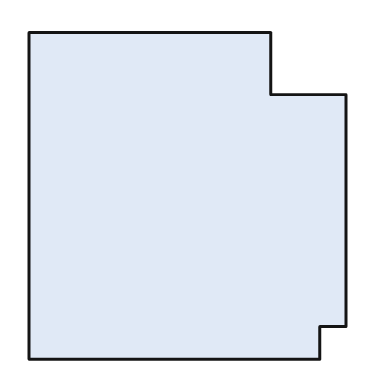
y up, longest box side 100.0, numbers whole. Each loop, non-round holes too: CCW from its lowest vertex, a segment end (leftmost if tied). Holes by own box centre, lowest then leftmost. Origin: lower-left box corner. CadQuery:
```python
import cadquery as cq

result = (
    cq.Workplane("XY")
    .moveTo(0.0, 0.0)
    .lineTo(89.0, 0.0)
    .lineTo(89.0, 10.0)
    .lineTo(97.0, 10.0)
    .lineTo(97.0, 81.0)
    .lineTo(74.0, 81.0)
    .lineTo(74.0, 100.0)
    .lineTo(0.0, 100.0)
    .close()
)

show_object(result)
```